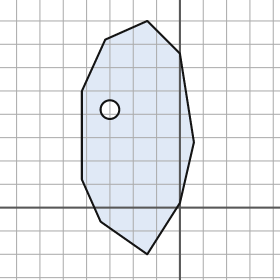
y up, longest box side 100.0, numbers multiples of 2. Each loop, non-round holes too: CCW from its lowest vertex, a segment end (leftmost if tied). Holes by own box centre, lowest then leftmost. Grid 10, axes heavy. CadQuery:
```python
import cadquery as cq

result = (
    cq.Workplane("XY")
    .moveTo(-14.0, -20.0)
    .lineTo(0.0, 2.0)
    .lineTo(6.0, 28.0)
    .lineTo(0.0, 66.0)
    .lineTo(-14.0, 80.0)
    .lineTo(-32.0, 72.0)
    .lineTo(-42.0, 50.0)
    .lineTo(-42.0, 12.0)
    .lineTo(-34.0, -6.0)
    .close()
    .moveTo(-30.0, 42.0)
    .circle(4.0)
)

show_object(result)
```